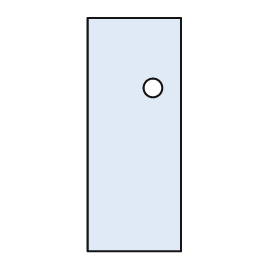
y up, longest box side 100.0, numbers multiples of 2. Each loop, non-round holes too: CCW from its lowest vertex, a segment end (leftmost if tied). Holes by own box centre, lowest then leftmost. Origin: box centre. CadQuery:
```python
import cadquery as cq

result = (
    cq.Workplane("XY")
    .moveTo(-20.0, -50.0)
    .lineTo(20.0, -50.0)
    .lineTo(20.0, 50.0)
    .lineTo(-20.0, 50.0)
    .close()
    .moveTo(8.0, 20.0)
    .circle(4.0)
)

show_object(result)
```